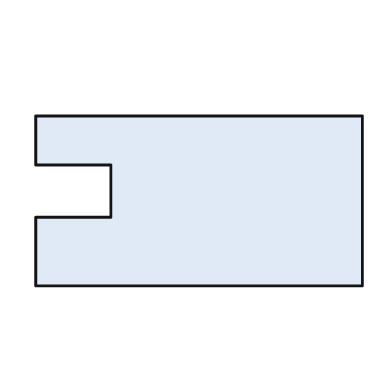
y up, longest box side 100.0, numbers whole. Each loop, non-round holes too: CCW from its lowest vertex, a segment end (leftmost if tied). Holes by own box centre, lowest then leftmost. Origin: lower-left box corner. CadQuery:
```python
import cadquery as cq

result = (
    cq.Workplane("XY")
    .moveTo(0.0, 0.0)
    .lineTo(100.0, 0.0)
    .lineTo(100.0, 52.0)
    .lineTo(0.0, 52.0)
    .lineTo(0.0, 37.0)
    .lineTo(23.0, 37.0)
    .lineTo(23.0, 21.0)
    .lineTo(0.0, 21.0)
    .close()
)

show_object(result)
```